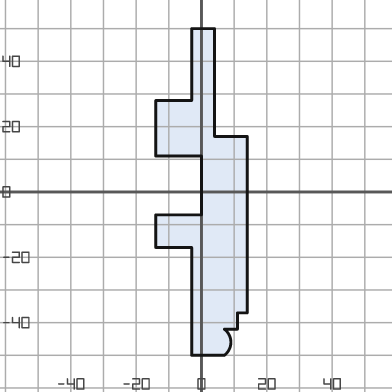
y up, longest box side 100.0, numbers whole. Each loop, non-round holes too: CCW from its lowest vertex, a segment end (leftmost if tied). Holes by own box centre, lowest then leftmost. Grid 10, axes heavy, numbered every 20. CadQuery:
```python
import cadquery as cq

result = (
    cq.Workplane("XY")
    .moveTo(-3.0, -50.0)
    .lineTo(7.0, -50.0)
    .threePointArc((9.0, -46.0), (7.0, -42.0))
    .lineTo(11.0, -42.0)
    .lineTo(11.0, -37.0)
    .lineTo(14.0, -37.0)
    .lineTo(14.0, 17.0)
    .lineTo(4.0, 17.0)
    .lineTo(4.0, 50.0)
    .lineTo(-3.0, 50.0)
    .lineTo(-3.0, 28.0)
    .lineTo(-14.0, 28.0)
    .lineTo(-14.0, 11.0)
    .lineTo(0.0, 11.0)
    .lineTo(0.0, -7.0)
    .lineTo(-14.0, -7.0)
    .lineTo(-14.0, -17.0)
    .lineTo(-3.0, -17.0)
    .close()
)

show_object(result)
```